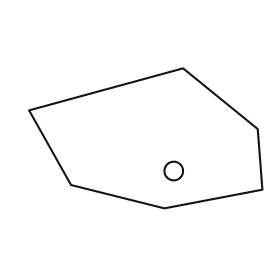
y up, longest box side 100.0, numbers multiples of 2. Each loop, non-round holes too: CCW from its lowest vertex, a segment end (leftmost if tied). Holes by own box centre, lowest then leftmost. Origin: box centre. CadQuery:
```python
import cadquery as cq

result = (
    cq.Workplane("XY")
    .moveTo(8.0, -30.0)
    .lineTo(50.0, -22.0)
    .lineTo(48.0, 4.0)
    .lineTo(16.0, 30.0)
    .lineTo(-50.0, 12.0)
    .lineTo(-32.0, -20.0)
    .close()
    .moveTo(12.0, -14.0)
    .circle(4.0)
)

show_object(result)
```